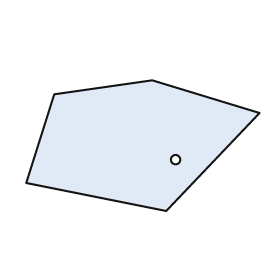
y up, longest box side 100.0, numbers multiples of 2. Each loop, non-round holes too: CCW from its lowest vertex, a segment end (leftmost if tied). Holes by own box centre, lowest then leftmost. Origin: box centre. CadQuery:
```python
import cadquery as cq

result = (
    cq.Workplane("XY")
    .moveTo(10.0, -28.0)
    .lineTo(50.0, 14.0)
    .lineTo(4.0, 28.0)
    .lineTo(-38.0, 22.0)
    .lineTo(-50.0, -16.0)
    .close()
    .moveTo(14.0, -6.0)
    .circle(2.0)
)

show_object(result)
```